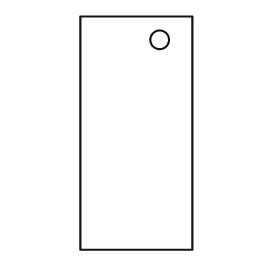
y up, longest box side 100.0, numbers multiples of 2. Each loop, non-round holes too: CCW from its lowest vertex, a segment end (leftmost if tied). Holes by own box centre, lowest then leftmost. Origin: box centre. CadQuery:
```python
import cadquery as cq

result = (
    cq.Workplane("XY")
    .moveTo(-24.0, -50.0)
    .lineTo(24.0, -50.0)
    .lineTo(24.0, 50.0)
    .lineTo(-24.0, 50.0)
    .close()
    .moveTo(10.0, 40.0)
    .circle(4.0)
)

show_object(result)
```